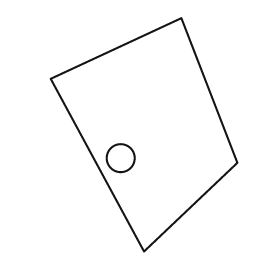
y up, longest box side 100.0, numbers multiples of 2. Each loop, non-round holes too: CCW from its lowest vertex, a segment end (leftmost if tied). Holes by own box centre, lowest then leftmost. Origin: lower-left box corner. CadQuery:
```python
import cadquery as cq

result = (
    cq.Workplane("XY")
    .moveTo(40.0, 0.0)
    .lineTo(80.0, 38.0)
    .lineTo(56.0, 100.0)
    .lineTo(0.0, 74.0)
    .close()
    .moveTo(30.0, 40.0)
    .circle(6.0)
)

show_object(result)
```